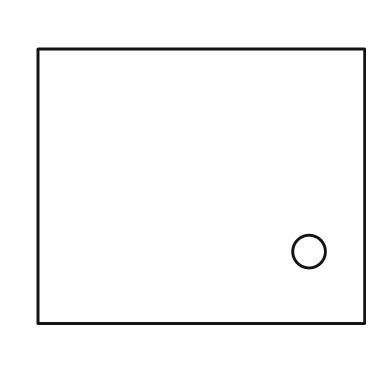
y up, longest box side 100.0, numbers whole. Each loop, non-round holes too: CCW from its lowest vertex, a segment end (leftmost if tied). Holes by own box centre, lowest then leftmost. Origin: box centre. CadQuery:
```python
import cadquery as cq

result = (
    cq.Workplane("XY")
    .moveTo(-50.0, -42.0)
    .lineTo(50.0, -42.0)
    .lineTo(50.0, 42.0)
    .lineTo(-50.0, 42.0)
    .close()
    .moveTo(33.0, -20.0)
    .circle(5.0)
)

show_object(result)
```